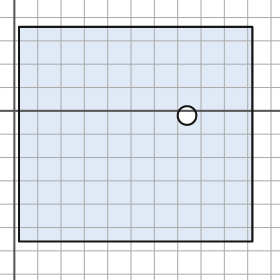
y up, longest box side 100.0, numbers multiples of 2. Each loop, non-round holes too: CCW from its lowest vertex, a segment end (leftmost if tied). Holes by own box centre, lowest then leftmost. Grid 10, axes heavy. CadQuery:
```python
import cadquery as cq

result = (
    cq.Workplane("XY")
    .moveTo(2.0, -56.0)
    .lineTo(102.0, -56.0)
    .lineTo(102.0, 36.0)
    .lineTo(2.0, 36.0)
    .close()
    .moveTo(74.0, -2.0)
    .circle(4.0)
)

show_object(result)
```